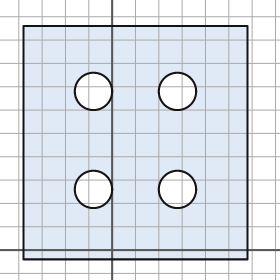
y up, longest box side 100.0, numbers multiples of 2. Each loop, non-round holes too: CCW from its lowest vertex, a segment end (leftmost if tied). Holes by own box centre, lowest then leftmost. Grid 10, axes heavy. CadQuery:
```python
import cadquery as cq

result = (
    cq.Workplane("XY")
    .moveTo(-38.0, -4.0)
    .lineTo(58.0, -4.0)
    .lineTo(58.0, 96.0)
    .lineTo(-38.0, 96.0)
    .close()
    .moveTo(-8.0, 26.0)
    .circle(8.0)
    .moveTo(28.0, 26.0)
    .circle(8.0)
    .moveTo(-8.0, 68.0)
    .circle(8.0)
    .moveTo(28.0, 68.0)
    .circle(8.0)
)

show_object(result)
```